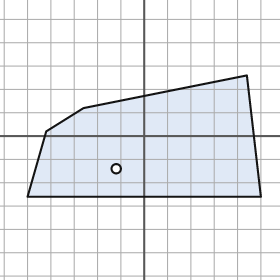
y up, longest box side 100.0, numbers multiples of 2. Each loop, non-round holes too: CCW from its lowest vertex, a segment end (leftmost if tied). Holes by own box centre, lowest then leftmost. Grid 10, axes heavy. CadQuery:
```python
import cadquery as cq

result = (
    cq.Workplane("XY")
    .moveTo(-50.0, -26.0)
    .lineTo(50.0, -26.0)
    .lineTo(44.0, 26.0)
    .lineTo(-26.0, 12.0)
    .lineTo(-42.0, 2.0)
    .close()
    .moveTo(-12.0, -14.0)
    .circle(2.0)
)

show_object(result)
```